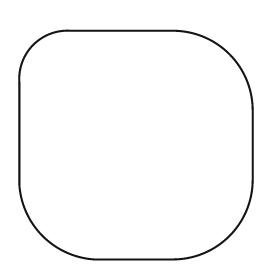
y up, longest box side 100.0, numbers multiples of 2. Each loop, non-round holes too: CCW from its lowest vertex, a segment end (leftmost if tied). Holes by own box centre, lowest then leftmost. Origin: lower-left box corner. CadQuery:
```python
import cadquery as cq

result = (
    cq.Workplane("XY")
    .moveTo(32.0, 0.0)
    .lineTo(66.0, 0.0)
    .threePointArc((90.0, 10.0), (100.0, 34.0))
    .lineTo(100.0, 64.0)
    .threePointArc((90.0, 88.0), (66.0, 98.0))
    .lineTo(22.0, 98.0)
    .threePointArc((6.0, 92.0), (0.0, 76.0))
    .lineTo(0.0, 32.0)
    .threePointArc((10.0, 10.0), (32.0, 0.0))
    .close()
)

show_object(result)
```